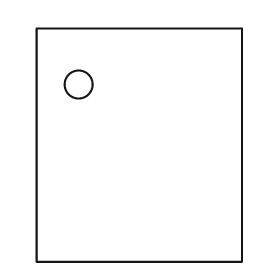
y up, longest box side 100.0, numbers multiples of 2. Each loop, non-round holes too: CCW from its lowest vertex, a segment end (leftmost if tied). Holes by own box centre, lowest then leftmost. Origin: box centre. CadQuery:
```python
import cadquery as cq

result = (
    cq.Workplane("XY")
    .moveTo(-44.0, -50.0)
    .lineTo(44.0, -50.0)
    .lineTo(44.0, 50.0)
    .lineTo(-44.0, 50.0)
    .close()
    .moveTo(-26.0, 26.0)
    .circle(6.0)
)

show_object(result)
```